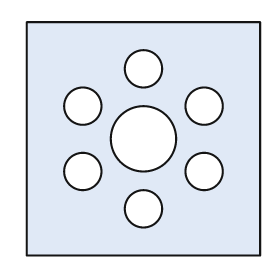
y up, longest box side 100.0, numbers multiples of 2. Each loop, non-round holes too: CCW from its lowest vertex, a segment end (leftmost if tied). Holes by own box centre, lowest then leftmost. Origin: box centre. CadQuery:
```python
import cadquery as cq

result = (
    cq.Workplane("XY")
    .moveTo(-50.0, -50.0)
    .lineTo(50.0, -50.0)
    .lineTo(50.0, 50.0)
    .lineTo(-50.0, 50.0)
    .close()
    .moveTo(0.0, -30.0)
    .circle(8.0)
    .moveTo(-26.0, -14.0)
    .circle(8.0)
    .moveTo(26.0, -14.0)
    .circle(8.0)
    .moveTo(0.0, 0.0)
    .circle(14.0)
    .moveTo(-26.0, 14.0)
    .circle(8.0)
    .moveTo(26.0, 14.0)
    .circle(8.0)
    .moveTo(0.0, 30.0)
    .circle(8.0)
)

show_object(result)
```